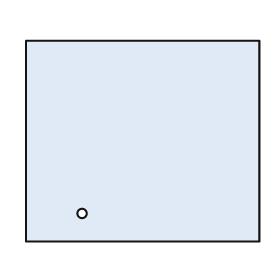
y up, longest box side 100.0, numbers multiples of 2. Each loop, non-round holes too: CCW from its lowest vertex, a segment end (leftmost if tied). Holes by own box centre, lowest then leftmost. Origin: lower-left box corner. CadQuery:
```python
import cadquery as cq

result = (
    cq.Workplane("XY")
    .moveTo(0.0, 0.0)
    .lineTo(100.0, 0.0)
    .lineTo(100.0, 86.0)
    .lineTo(0.0, 86.0)
    .close()
    .moveTo(24.0, 12.0)
    .circle(2.0)
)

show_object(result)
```